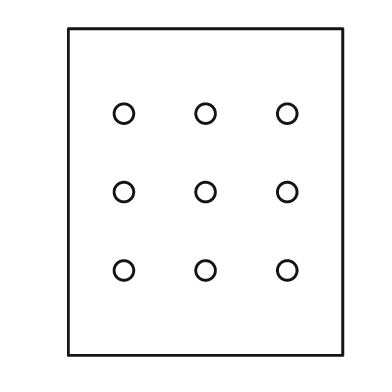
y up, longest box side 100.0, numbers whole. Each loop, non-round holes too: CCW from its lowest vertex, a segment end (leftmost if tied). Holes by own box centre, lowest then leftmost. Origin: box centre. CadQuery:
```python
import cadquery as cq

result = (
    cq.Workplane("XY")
    .moveTo(-42.0, -50.0)
    .lineTo(42.0, -50.0)
    .lineTo(42.0, 50.0)
    .lineTo(-42.0, 50.0)
    .close()
    .moveTo(-25.0, -24.0)
    .circle(3.0)
    .moveTo(0.0, -24.0)
    .circle(3.0)
    .moveTo(25.0, -24.0)
    .circle(3.0)
    .moveTo(-25.0, 0.0)
    .circle(3.0)
    .moveTo(0.0, 0.0)
    .circle(3.0)
    .moveTo(25.0, 0.0)
    .circle(3.0)
    .moveTo(-25.0, 24.0)
    .circle(3.0)
    .moveTo(0.0, 24.0)
    .circle(3.0)
    .moveTo(25.0, 24.0)
    .circle(3.0)
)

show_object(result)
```